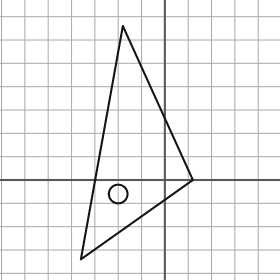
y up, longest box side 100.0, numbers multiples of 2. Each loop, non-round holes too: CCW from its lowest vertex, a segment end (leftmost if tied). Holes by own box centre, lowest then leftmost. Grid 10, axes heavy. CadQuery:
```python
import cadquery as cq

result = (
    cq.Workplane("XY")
    .moveTo(-36.0, -34.0)
    .lineTo(12.0, 0.0)
    .lineTo(-18.0, 66.0)
    .close()
    .moveTo(-20.0, -6.0)
    .circle(4.0)
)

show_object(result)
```